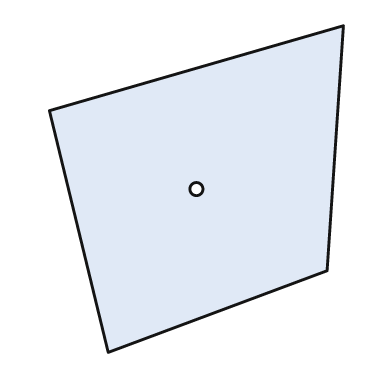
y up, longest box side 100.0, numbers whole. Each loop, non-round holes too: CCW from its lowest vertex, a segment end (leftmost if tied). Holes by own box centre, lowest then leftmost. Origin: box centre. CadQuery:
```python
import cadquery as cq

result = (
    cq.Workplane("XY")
    .moveTo(-27.0, -50.0)
    .lineTo(40.0, -25.0)
    .lineTo(45.0, 50.0)
    .lineTo(-45.0, 24.0)
    .close()
    .moveTo(0.0, 0.0)
    .circle(2.0)
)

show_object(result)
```